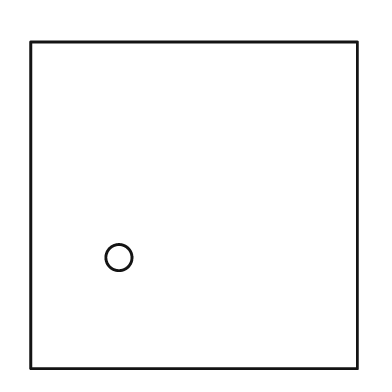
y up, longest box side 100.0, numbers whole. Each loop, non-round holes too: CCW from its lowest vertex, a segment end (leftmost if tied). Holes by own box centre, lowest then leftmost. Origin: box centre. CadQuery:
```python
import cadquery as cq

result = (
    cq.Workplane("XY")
    .moveTo(-50.0, -50.0)
    .lineTo(50.0, -50.0)
    .lineTo(50.0, 50.0)
    .lineTo(-50.0, 50.0)
    .close()
    .moveTo(-23.0, -16.0)
    .circle(4.0)
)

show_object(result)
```